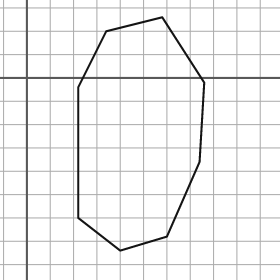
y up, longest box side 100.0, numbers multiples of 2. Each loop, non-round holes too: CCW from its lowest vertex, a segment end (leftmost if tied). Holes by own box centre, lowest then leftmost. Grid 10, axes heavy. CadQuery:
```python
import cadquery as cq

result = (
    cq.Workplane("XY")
    .moveTo(40.0, -74.0)
    .lineTo(60.0, -68.0)
    .lineTo(74.0, -36.0)
    .lineTo(76.0, -2.0)
    .lineTo(58.0, 26.0)
    .lineTo(34.0, 20.0)
    .lineTo(22.0, -4.0)
    .lineTo(22.0, -60.0)
    .close()
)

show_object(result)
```